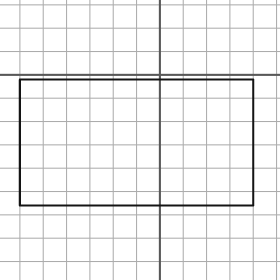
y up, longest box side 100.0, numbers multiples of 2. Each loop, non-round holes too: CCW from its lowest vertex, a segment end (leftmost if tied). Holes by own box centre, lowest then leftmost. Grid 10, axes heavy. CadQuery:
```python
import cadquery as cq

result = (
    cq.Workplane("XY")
    .moveTo(-60.0, -56.0)
    .lineTo(40.0, -56.0)
    .lineTo(40.0, -2.0)
    .lineTo(-60.0, -2.0)
    .close()
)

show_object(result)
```